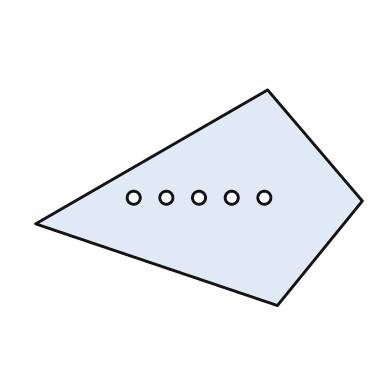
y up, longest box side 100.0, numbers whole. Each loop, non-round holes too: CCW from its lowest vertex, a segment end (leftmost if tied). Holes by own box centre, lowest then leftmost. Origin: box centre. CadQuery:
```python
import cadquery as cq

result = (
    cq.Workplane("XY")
    .moveTo(24.0, -33.0)
    .lineTo(50.0, -1.0)
    .lineTo(21.0, 33.0)
    .lineTo(-50.0, -8.0)
    .close()
    .moveTo(-20.0, 0.0)
    .circle(2.0)
    .moveTo(-10.0, 0.0)
    .circle(2.0)
    .moveTo(0.0, 0.0)
    .circle(2.0)
    .moveTo(10.0, 0.0)
    .circle(2.0)
    .moveTo(20.0, 0.0)
    .circle(2.0)
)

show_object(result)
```